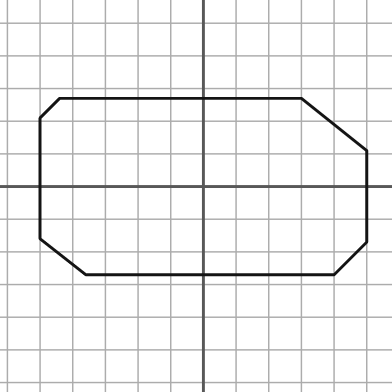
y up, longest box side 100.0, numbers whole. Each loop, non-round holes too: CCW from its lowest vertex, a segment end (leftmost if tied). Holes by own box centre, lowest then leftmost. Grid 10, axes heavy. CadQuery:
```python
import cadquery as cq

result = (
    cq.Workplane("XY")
    .moveTo(-36.0, -27.0)
    .lineTo(40.0, -27.0)
    .lineTo(50.0, -17.0)
    .lineTo(50.0, 11.0)
    .lineTo(30.0, 27.0)
    .lineTo(-44.0, 27.0)
    .lineTo(-50.0, 21.0)
    .lineTo(-50.0, -16.0)
    .close()
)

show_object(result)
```